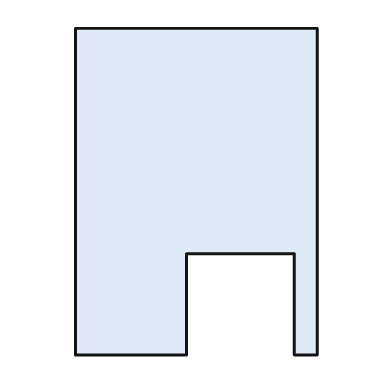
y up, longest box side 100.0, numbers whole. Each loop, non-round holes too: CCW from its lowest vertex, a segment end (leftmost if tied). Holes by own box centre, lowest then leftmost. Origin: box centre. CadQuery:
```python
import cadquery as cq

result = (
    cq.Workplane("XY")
    .moveTo(-37.0, -50.0)
    .lineTo(-3.0, -50.0)
    .lineTo(-3.0, -19.0)
    .lineTo(30.0, -19.0)
    .lineTo(30.0, -50.0)
    .lineTo(37.0, -50.0)
    .lineTo(37.0, 50.0)
    .lineTo(-37.0, 50.0)
    .close()
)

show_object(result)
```